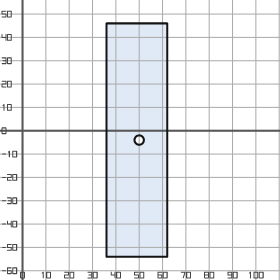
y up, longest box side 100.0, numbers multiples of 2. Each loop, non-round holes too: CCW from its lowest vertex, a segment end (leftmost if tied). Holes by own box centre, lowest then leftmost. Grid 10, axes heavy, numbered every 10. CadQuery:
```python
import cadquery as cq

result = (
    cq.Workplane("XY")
    .moveTo(36.0, -54.0)
    .lineTo(62.0, -54.0)
    .lineTo(62.0, 46.0)
    .lineTo(36.0, 46.0)
    .close()
    .moveTo(50.0, -4.0)
    .circle(2.0)
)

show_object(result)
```